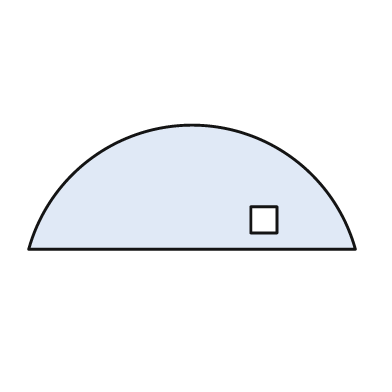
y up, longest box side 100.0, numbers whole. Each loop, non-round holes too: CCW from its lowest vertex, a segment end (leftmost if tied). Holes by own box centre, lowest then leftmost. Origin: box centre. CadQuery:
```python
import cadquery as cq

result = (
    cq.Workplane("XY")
    .moveTo(-50.0, -19.0)
    .lineTo(50.0, -19.0)
    .threePointArc((0.0, 19.0), (-50.0, -19.0))
    .close()
    .moveTo(18.0, -14.0)
    .lineTo(26.0, -14.0)
    .lineTo(26.0, -6.0)
    .lineTo(18.0, -6.0)
    .close()
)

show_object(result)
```